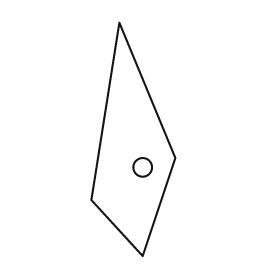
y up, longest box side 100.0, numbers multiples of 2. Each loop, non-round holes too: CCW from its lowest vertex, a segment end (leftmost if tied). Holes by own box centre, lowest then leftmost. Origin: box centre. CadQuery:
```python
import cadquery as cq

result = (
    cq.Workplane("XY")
    .moveTo(4.0, -50.0)
    .lineTo(18.0, -8.0)
    .lineTo(-6.0, 50.0)
    .lineTo(-18.0, -26.0)
    .close()
    .moveTo(4.0, -12.0)
    .circle(4.0)
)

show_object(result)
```